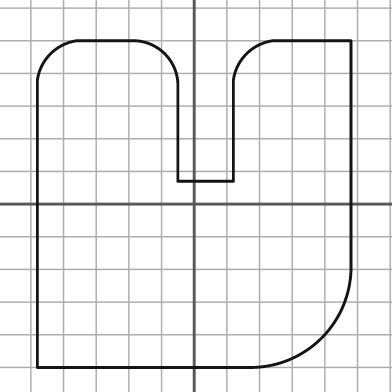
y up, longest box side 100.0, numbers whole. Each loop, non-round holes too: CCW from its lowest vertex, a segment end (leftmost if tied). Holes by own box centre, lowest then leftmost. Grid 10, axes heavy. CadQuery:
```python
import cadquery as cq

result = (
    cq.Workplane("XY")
    .moveTo(-48.0, -50.0)
    .lineTo(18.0, -50.0)
    .threePointArc((39.0, -41.0), (48.0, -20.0))
    .lineTo(48.0, 50.0)
    .lineTo(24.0, 50.0)
    .threePointArc((16.0, 46.0), (12.0, 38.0))
    .lineTo(12.0, 7.0)
    .lineTo(-5.0, 7.0)
    .lineTo(-5.0, 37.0)
    .threePointArc((-9.0, 46.0), (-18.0, 50.0))
    .lineTo(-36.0, 50.0)
    .threePointArc((-44.0, 46.0), (-48.0, 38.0))
    .close()
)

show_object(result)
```